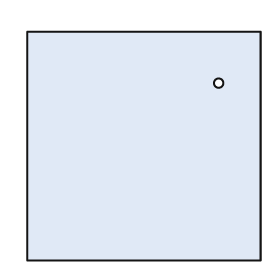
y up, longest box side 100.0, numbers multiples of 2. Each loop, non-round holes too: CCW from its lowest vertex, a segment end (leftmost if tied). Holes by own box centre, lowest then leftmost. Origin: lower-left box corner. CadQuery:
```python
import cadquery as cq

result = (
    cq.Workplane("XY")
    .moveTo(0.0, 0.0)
    .lineTo(100.0, 0.0)
    .lineTo(100.0, 98.0)
    .lineTo(0.0, 98.0)
    .close()
    .moveTo(82.0, 76.0)
    .circle(2.0)
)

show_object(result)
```